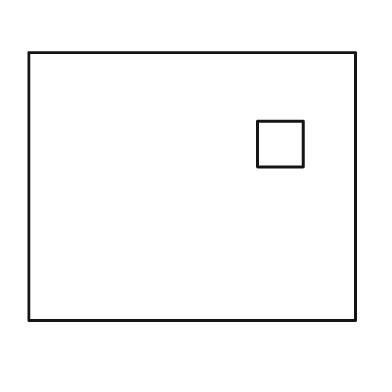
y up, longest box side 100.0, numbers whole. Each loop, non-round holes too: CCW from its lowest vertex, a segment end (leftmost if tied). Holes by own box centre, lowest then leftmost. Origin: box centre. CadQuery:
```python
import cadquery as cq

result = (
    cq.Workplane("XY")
    .moveTo(-50.0, -41.0)
    .lineTo(50.0, -41.0)
    .lineTo(50.0, 41.0)
    .lineTo(-50.0, 41.0)
    .close()
    .moveTo(20.0, 6.0)
    .lineTo(34.0, 6.0)
    .lineTo(34.0, 20.0)
    .lineTo(20.0, 20.0)
    .close()
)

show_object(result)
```